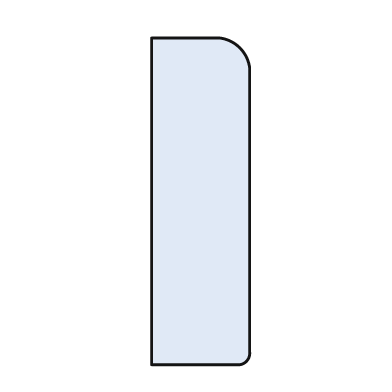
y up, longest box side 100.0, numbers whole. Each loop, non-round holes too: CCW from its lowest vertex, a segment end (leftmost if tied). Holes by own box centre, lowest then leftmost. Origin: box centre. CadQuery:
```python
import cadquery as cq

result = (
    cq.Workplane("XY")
    .moveTo(-15.0, -50.0)
    .lineTo(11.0, -50.0)
    .threePointArc((14.0, -49.0), (15.0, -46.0))
    .lineTo(15.0, 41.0)
    .threePointArc((12.0, 47.0), (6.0, 50.0))
    .lineTo(-15.0, 50.0)
    .close()
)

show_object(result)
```